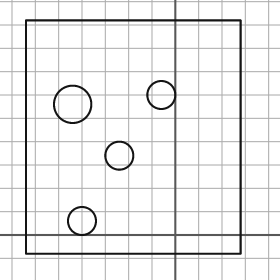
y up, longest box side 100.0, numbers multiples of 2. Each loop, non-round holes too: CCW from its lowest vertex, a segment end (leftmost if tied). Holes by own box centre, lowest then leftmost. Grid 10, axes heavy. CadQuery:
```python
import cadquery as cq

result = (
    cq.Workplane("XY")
    .moveTo(-64.0, -8.0)
    .lineTo(28.0, -8.0)
    .lineTo(28.0, 92.0)
    .lineTo(-64.0, 92.0)
    .close()
    .moveTo(-40.0, 6.0)
    .circle(6.0)
    .moveTo(-24.0, 34.0)
    .circle(6.0)
    .moveTo(-44.0, 56.0)
    .circle(8.0)
    .moveTo(-6.0, 60.0)
    .circle(6.0)
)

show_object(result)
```